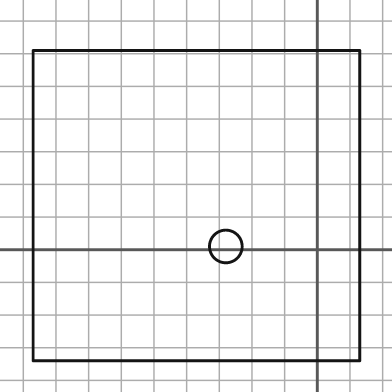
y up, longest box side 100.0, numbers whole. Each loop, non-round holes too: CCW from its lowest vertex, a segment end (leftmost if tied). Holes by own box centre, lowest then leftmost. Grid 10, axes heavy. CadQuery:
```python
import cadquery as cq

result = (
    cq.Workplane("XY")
    .moveTo(-87.0, -34.0)
    .lineTo(13.0, -34.0)
    .lineTo(13.0, 61.0)
    .lineTo(-87.0, 61.0)
    .close()
    .moveTo(-28.0, 1.0)
    .circle(5.0)
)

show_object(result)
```